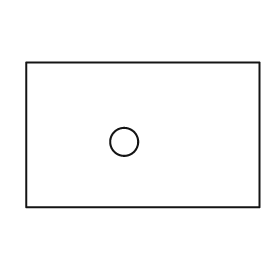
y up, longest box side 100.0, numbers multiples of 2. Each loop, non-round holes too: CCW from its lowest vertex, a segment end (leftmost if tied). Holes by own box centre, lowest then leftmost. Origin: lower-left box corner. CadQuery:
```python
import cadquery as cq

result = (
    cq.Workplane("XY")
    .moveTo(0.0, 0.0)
    .lineTo(100.0, 0.0)
    .lineTo(100.0, 62.0)
    .lineTo(0.0, 62.0)
    .close()
    .moveTo(42.0, 28.0)
    .circle(6.0)
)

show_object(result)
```